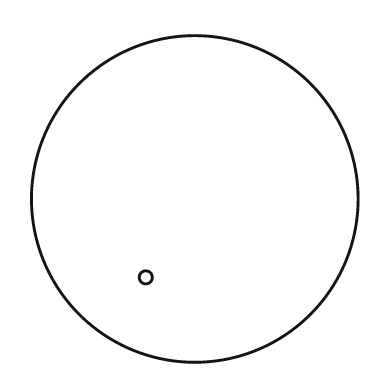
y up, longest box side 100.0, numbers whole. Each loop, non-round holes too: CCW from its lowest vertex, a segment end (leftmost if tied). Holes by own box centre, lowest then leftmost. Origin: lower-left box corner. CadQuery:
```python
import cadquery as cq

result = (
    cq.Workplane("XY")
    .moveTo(50.0, 50.0)
    .circle(50.0)
    .moveTo(35.0, 26.0)
    .circle(2.0)
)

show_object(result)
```